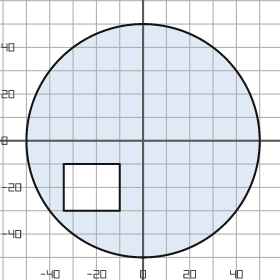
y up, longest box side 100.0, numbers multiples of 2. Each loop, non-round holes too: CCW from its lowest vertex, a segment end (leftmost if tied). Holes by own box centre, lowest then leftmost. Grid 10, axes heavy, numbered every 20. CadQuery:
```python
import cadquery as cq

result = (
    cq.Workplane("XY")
    .moveTo(0.0, 0.0)
    .circle(50.0)
    .moveTo(-34.0, -30.0)
    .lineTo(-10.0, -30.0)
    .lineTo(-10.0, -10.0)
    .lineTo(-34.0, -10.0)
    .close()
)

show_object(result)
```